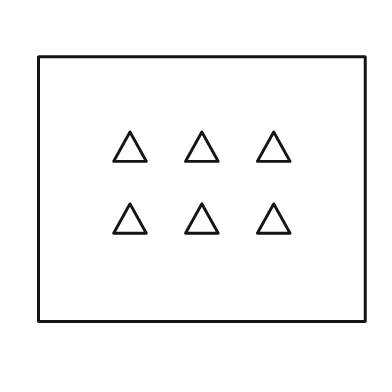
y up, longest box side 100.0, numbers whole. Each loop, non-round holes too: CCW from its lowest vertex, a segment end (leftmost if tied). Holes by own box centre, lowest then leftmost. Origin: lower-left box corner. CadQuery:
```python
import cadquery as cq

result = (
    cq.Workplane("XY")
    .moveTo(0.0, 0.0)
    .lineTo(100.0, 0.0)
    .lineTo(100.0, 81.0)
    .lineTo(0.0, 81.0)
    .close()
    .moveTo(23.0, 27.0)
    .lineTo(33.0, 27.0)
    .lineTo(28.0, 36.0)
    .close()
    .moveTo(45.0, 27.0)
    .lineTo(55.0, 27.0)
    .lineTo(50.0, 36.0)
    .close()
    .moveTo(67.0, 27.0)
    .lineTo(77.0, 27.0)
    .lineTo(72.0, 36.0)
    .close()
    .moveTo(23.0, 49.0)
    .lineTo(33.0, 49.0)
    .lineTo(28.0, 58.0)
    .close()
    .moveTo(45.0, 49.0)
    .lineTo(55.0, 49.0)
    .lineTo(50.0, 58.0)
    .close()
    .moveTo(67.0, 49.0)
    .lineTo(77.0, 49.0)
    .lineTo(72.0, 58.0)
    .close()
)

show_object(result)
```